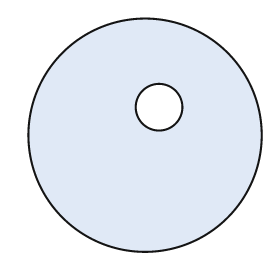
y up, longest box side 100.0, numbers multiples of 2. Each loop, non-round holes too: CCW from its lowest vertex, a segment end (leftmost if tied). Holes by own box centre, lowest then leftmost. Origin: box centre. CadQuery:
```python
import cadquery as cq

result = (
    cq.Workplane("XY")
    .moveTo(0.0, 0.0)
    .circle(50.0)
    .moveTo(6.0, 12.0)
    .circle(10.0)
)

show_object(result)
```